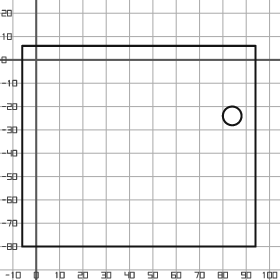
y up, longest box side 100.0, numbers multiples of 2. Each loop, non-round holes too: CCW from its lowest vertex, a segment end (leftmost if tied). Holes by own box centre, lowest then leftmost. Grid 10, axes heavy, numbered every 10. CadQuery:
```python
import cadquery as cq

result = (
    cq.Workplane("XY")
    .moveTo(-6.0, -80.0)
    .lineTo(94.0, -80.0)
    .lineTo(94.0, 6.0)
    .lineTo(-6.0, 6.0)
    .close()
    .moveTo(84.0, -24.0)
    .circle(4.0)
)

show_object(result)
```